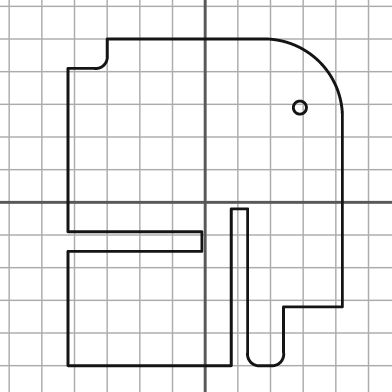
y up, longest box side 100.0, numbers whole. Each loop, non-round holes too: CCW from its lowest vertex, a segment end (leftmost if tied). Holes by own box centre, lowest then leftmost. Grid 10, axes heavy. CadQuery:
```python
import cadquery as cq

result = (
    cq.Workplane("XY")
    .moveTo(-42.0, -50.0)
    .lineTo(8.0, -50.0)
    .lineTo(8.0, -2.0)
    .lineTo(13.0, -2.0)
    .lineTo(13.0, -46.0)
    .threePointArc((14.0, -49.0), (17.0, -50.0))
    .lineTo(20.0, -50.0)
    .threePointArc((23.0, -49.0), (24.0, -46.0))
    .lineTo(24.0, -32.0)
    .lineTo(42.0, -32.0)
    .lineTo(42.0, 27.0)
    .threePointArc((35.0, 43.0), (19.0, 50.0))
    .lineTo(-30.0, 50.0)
    .lineTo(-30.0, 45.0)
    .threePointArc((-31.0, 42.0), (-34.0, 41.0))
    .lineTo(-42.0, 41.0)
    .lineTo(-42.0, -9.0)
    .lineTo(-1.0, -9.0)
    .lineTo(-1.0, -15.0)
    .lineTo(-42.0, -15.0)
    .close()
    .moveTo(29.0, 29.0)
    .circle(2.0)
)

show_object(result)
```